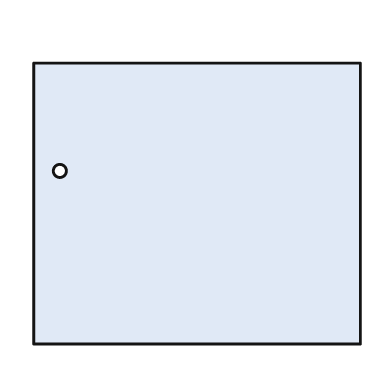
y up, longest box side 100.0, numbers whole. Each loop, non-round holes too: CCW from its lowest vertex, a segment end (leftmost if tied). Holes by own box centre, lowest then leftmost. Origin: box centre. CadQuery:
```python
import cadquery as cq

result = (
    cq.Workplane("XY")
    .moveTo(-50.0, -43.0)
    .lineTo(50.0, -43.0)
    .lineTo(50.0, 43.0)
    .lineTo(-50.0, 43.0)
    .close()
    .moveTo(-42.0, 10.0)
    .circle(2.0)
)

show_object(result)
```